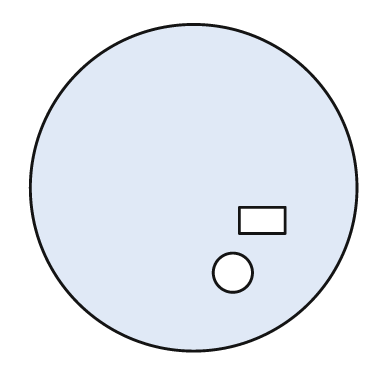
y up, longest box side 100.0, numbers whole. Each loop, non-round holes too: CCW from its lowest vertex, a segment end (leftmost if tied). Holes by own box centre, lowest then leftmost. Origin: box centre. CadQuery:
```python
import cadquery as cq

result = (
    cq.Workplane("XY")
    .moveTo(0.0, 0.0)
    .circle(50.0)
    .moveTo(12.0, -26.0)
    .circle(6.0)
    .moveTo(14.0, -14.0)
    .lineTo(28.0, -14.0)
    .lineTo(28.0, -6.0)
    .lineTo(14.0, -6.0)
    .close()
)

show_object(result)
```